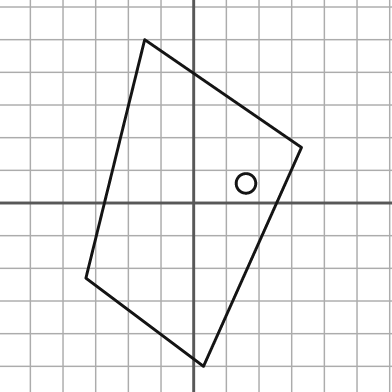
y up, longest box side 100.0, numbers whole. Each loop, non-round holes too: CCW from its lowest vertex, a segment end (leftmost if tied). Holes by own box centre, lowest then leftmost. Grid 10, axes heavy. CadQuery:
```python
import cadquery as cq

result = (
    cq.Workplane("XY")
    .moveTo(3.0, -50.0)
    .lineTo(33.0, 17.0)
    .lineTo(-15.0, 50.0)
    .lineTo(-33.0, -23.0)
    .close()
    .moveTo(16.0, 6.0)
    .circle(3.0)
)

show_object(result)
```